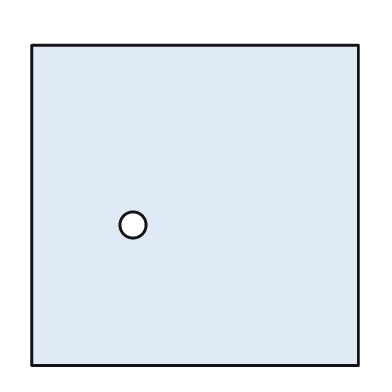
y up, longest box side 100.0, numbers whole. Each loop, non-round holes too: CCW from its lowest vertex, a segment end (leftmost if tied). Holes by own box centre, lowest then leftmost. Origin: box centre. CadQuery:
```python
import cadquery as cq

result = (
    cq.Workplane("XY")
    .moveTo(-50.0, -49.0)
    .lineTo(50.0, -49.0)
    .lineTo(50.0, 49.0)
    .lineTo(-50.0, 49.0)
    .close()
    .moveTo(-19.0, -6.0)
    .circle(4.0)
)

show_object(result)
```